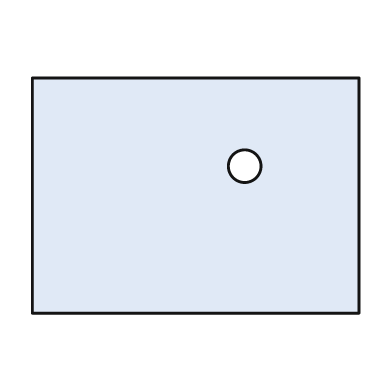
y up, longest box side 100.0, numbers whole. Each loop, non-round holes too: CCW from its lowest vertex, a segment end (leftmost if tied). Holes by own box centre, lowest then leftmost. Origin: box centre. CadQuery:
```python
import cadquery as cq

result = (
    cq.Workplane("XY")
    .moveTo(-50.0, -36.0)
    .lineTo(50.0, -36.0)
    .lineTo(50.0, 36.0)
    .lineTo(-50.0, 36.0)
    .close()
    .moveTo(15.0, 9.0)
    .circle(5.0)
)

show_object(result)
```